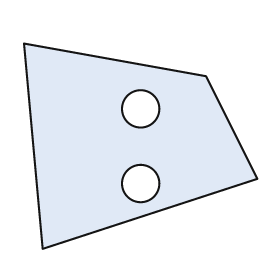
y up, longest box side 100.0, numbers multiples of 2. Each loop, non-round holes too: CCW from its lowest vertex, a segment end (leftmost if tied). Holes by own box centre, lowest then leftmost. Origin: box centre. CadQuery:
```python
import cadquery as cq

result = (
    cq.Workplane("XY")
    .moveTo(-42.0, -44.0)
    .lineTo(50.0, -14.0)
    .lineTo(28.0, 30.0)
    .lineTo(-50.0, 44.0)
    .close()
    .moveTo(0.0, -16.0)
    .circle(8.0)
    .moveTo(0.0, 16.0)
    .circle(8.0)
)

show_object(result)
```